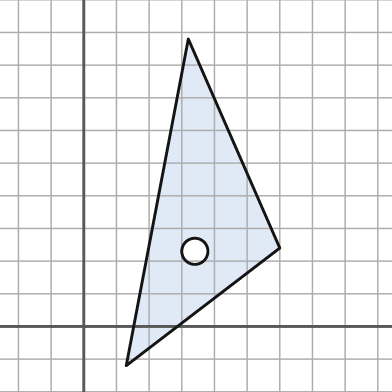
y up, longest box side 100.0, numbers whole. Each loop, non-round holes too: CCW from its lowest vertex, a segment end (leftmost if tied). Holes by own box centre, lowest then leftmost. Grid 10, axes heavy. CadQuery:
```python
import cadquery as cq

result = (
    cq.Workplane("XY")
    .moveTo(13.0, -12.0)
    .lineTo(60.0, 24.0)
    .lineTo(32.0, 88.0)
    .close()
    .moveTo(34.0, 23.0)
    .circle(4.0)
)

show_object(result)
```